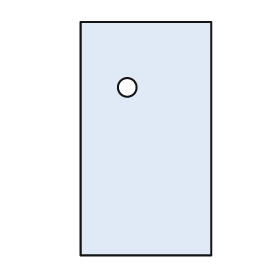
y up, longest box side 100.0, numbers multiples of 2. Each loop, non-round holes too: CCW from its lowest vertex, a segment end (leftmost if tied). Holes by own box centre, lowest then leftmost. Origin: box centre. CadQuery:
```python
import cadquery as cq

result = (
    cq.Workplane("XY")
    .moveTo(-28.0, -50.0)
    .lineTo(28.0, -50.0)
    .lineTo(28.0, 50.0)
    .lineTo(-28.0, 50.0)
    .close()
    .moveTo(-8.0, 22.0)
    .circle(4.0)
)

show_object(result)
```